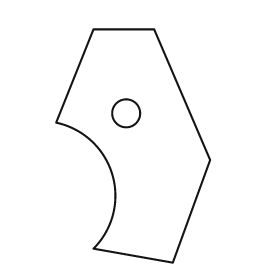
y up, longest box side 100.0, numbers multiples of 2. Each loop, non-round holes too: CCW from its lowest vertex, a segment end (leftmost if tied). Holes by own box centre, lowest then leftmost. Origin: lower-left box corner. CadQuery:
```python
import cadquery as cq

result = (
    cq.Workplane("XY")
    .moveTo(50.0, 0.0)
    .lineTo(66.0, 44.0)
    .lineTo(42.0, 100.0)
    .lineTo(16.0, 100.0)
    .lineTo(0.0, 60.0)
    .threePointArc((24.0, 38.0), (16.0, 6.0))
    .close()
    .moveTo(30.0, 64.0)
    .circle(6.0)
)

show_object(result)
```